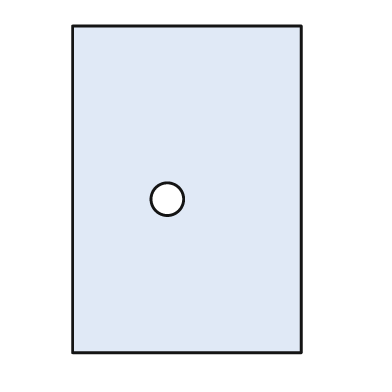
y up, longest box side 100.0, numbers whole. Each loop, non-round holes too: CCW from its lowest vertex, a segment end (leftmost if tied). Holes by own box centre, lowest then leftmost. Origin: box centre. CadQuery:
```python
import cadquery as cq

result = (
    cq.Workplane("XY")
    .moveTo(-35.0, -50.0)
    .lineTo(35.0, -50.0)
    .lineTo(35.0, 50.0)
    .lineTo(-35.0, 50.0)
    .close()
    .moveTo(-6.0, -3.0)
    .circle(5.0)
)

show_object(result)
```